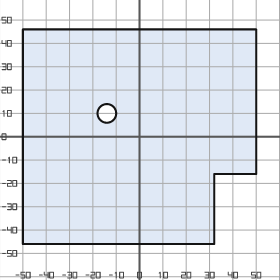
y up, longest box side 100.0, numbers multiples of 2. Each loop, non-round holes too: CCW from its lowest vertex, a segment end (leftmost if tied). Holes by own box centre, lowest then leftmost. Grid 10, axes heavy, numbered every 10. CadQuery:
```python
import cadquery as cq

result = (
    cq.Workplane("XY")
    .moveTo(-50.0, -46.0)
    .lineTo(32.0, -46.0)
    .lineTo(32.0, -16.0)
    .lineTo(50.0, -16.0)
    .lineTo(50.0, 46.0)
    .lineTo(-50.0, 46.0)
    .close()
    .moveTo(-14.0, 10.0)
    .circle(4.0)
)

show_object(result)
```